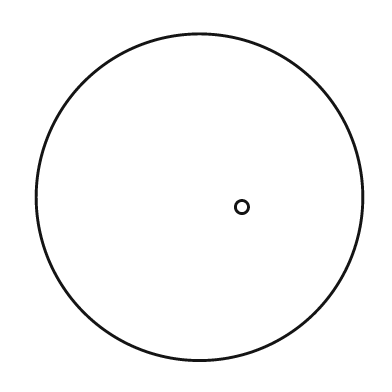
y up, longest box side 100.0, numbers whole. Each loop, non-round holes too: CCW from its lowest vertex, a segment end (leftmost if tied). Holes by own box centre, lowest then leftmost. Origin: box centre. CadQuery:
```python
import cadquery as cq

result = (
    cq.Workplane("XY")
    .moveTo(0.0, 0.0)
    .circle(50.0)
    .moveTo(13.0, -3.0)
    .circle(2.0)
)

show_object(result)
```